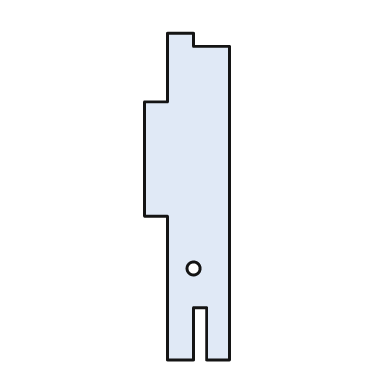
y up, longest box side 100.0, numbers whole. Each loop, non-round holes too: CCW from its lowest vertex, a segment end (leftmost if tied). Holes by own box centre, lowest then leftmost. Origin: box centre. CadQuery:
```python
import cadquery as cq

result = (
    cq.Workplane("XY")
    .moveTo(-6.0, -50.0)
    .lineTo(2.0, -50.0)
    .lineTo(2.0, -34.0)
    .lineTo(6.0, -34.0)
    .lineTo(6.0, -50.0)
    .lineTo(13.0, -50.0)
    .lineTo(13.0, 46.0)
    .lineTo(2.0, 46.0)
    .lineTo(2.0, 50.0)
    .lineTo(-6.0, 50.0)
    .lineTo(-6.0, 29.0)
    .lineTo(-13.0, 29.0)
    .lineTo(-13.0, -6.0)
    .lineTo(-6.0, -6.0)
    .close()
    .moveTo(2.0, -22.0)
    .circle(2.0)
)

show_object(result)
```